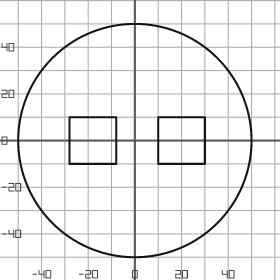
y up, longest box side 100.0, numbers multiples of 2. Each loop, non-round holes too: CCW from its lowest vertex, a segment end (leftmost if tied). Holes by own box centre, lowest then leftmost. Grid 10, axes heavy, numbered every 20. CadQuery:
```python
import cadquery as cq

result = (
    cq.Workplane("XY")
    .moveTo(0.0, 0.0)
    .circle(50.0)
    .moveTo(-28.0, -10.0)
    .lineTo(-8.0, -10.0)
    .lineTo(-8.0, 10.0)
    .lineTo(-28.0, 10.0)
    .close()
    .moveTo(10.0, -10.0)
    .lineTo(30.0, -10.0)
    .lineTo(30.0, 10.0)
    .lineTo(10.0, 10.0)
    .close()
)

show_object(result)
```